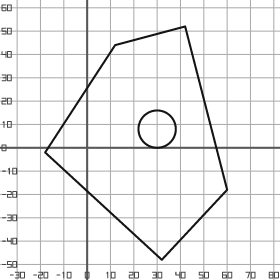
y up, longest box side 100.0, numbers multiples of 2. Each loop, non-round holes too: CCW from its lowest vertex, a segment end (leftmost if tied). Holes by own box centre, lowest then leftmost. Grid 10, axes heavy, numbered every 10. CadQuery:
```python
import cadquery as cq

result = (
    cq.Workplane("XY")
    .moveTo(32.0, -48.0)
    .lineTo(60.0, -18.0)
    .lineTo(42.0, 52.0)
    .lineTo(12.0, 44.0)
    .lineTo(-18.0, -2.0)
    .close()
    .moveTo(30.0, 8.0)
    .circle(8.0)
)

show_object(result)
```